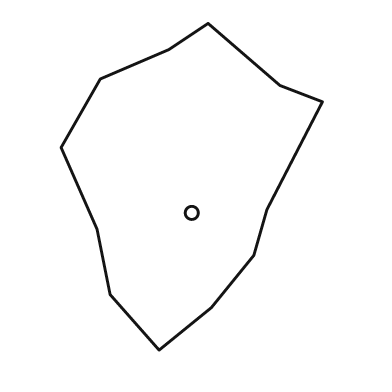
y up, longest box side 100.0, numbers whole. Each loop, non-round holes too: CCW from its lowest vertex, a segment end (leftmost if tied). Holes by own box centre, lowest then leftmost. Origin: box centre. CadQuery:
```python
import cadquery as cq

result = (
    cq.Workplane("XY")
    .moveTo(-10.0, -50.0)
    .lineTo(6.0, -37.0)
    .lineTo(19.0, -21.0)
    .lineTo(23.0, -7.0)
    .lineTo(40.0, 26.0)
    .lineTo(27.0, 31.0)
    .lineTo(5.0, 50.0)
    .lineTo(-7.0, 42.0)
    .lineTo(-28.0, 33.0)
    .lineTo(-40.0, 12.0)
    .lineTo(-29.0, -13.0)
    .lineTo(-25.0, -33.0)
    .close()
    .moveTo(0.0, -8.0)
    .circle(2.0)
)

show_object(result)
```